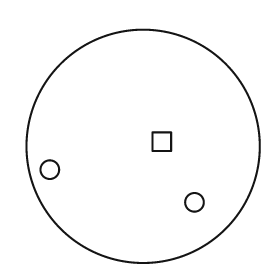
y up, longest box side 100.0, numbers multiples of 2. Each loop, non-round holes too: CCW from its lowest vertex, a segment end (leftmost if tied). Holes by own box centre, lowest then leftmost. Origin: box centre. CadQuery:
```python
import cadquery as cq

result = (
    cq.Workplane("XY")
    .moveTo(0.0, 0.0)
    .circle(50.0)
    .moveTo(22.0, -24.0)
    .circle(4.0)
    .moveTo(-40.0, -10.0)
    .circle(4.0)
    .moveTo(4.0, -2.0)
    .lineTo(12.0, -2.0)
    .lineTo(12.0, 6.0)
    .lineTo(4.0, 6.0)
    .close()
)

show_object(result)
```